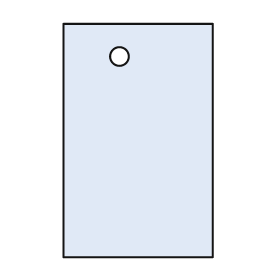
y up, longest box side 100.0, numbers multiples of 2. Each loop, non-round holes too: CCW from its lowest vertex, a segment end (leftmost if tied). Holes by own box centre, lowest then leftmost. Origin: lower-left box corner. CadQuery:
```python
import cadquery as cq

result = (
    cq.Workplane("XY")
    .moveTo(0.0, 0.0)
    .lineTo(64.0, 0.0)
    .lineTo(64.0, 100.0)
    .lineTo(0.0, 100.0)
    .close()
    .moveTo(24.0, 86.0)
    .circle(4.0)
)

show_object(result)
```